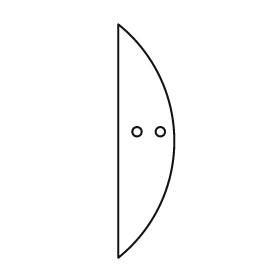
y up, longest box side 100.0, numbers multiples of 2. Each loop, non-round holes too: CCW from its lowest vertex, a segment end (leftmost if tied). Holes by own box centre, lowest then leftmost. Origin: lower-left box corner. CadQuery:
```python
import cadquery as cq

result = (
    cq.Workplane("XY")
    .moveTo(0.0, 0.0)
    .threePointArc((24.0, 50.0), (0.0, 100.0))
    .close()
    .moveTo(8.0, 54.0)
    .circle(2.0)
    .moveTo(18.0, 54.0)
    .circle(2.0)
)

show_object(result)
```